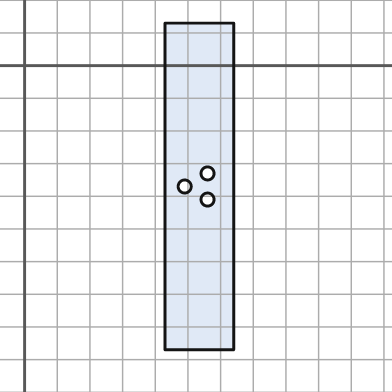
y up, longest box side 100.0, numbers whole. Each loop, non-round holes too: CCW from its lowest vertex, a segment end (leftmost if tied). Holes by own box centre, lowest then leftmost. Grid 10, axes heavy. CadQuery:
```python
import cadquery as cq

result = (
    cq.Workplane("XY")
    .moveTo(43.0, -87.0)
    .lineTo(64.0, -87.0)
    .lineTo(64.0, 13.0)
    .lineTo(43.0, 13.0)
    .close()
    .moveTo(56.0, -41.0)
    .circle(2.0)
    .moveTo(49.0, -37.0)
    .circle(2.0)
    .moveTo(56.0, -33.0)
    .circle(2.0)
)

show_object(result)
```